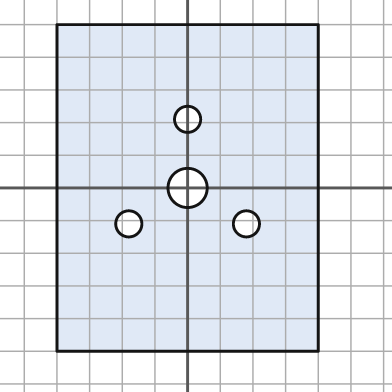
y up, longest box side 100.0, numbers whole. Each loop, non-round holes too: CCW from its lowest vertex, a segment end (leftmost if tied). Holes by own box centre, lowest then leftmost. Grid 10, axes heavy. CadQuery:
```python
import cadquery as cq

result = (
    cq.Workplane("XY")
    .moveTo(-40.0, -50.0)
    .lineTo(40.0, -50.0)
    .lineTo(40.0, 50.0)
    .lineTo(-40.0, 50.0)
    .close()
    .moveTo(-18.0, -11.0)
    .circle(4.0)
    .moveTo(18.0, -11.0)
    .circle(4.0)
    .moveTo(0.0, 0.0)
    .circle(6.0)
    .moveTo(0.0, 21.0)
    .circle(4.0)
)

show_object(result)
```